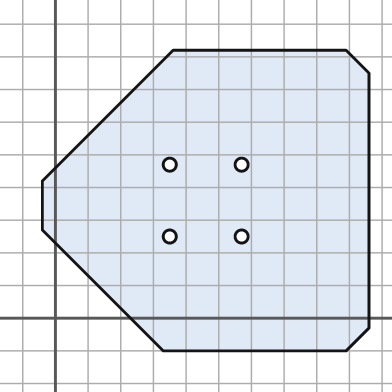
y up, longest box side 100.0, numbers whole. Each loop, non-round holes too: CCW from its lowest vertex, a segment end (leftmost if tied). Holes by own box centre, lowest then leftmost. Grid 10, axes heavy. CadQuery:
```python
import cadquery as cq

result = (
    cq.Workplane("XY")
    .moveTo(33.0, -10.0)
    .lineTo(89.0, -10.0)
    .lineTo(96.0, -3.0)
    .lineTo(96.0, 75.0)
    .lineTo(89.0, 82.0)
    .lineTo(36.0, 82.0)
    .lineTo(-4.0, 42.0)
    .lineTo(-4.0, 27.0)
    .close()
    .moveTo(35.0, 25.0)
    .circle(2.0)
    .moveTo(57.0, 25.0)
    .circle(2.0)
    .moveTo(35.0, 47.0)
    .circle(2.0)
    .moveTo(57.0, 47.0)
    .circle(2.0)
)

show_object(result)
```